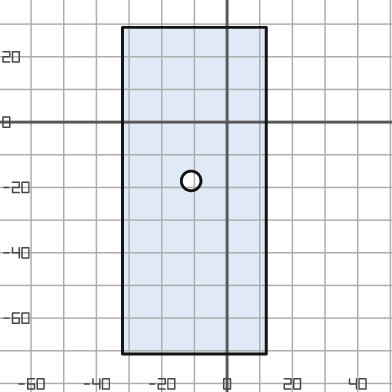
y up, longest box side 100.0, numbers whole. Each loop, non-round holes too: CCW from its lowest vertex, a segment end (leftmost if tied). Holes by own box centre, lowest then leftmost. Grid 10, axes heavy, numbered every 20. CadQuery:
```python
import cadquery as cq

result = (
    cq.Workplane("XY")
    .moveTo(-32.0, -71.0)
    .lineTo(12.0, -71.0)
    .lineTo(12.0, 29.0)
    .lineTo(-32.0, 29.0)
    .close()
    .moveTo(-11.0, -18.0)
    .circle(3.0)
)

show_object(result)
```